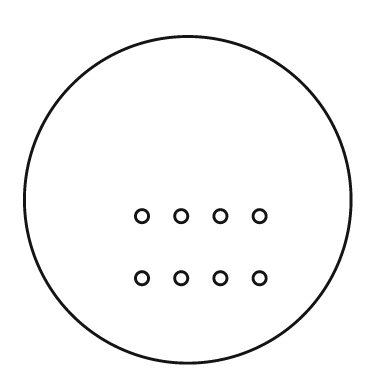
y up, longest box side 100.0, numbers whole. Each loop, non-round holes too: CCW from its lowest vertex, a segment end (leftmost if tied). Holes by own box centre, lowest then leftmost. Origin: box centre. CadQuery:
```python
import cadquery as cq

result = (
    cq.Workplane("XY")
    .moveTo(0.0, 0.0)
    .circle(50.0)
    .moveTo(-14.0, -24.0)
    .circle(2.0)
    .moveTo(-2.0, -24.0)
    .circle(2.0)
    .moveTo(10.0, -24.0)
    .circle(2.0)
    .moveTo(22.0, -24.0)
    .circle(2.0)
    .moveTo(-14.0, -5.0)
    .circle(2.0)
    .moveTo(-2.0, -5.0)
    .circle(2.0)
    .moveTo(10.0, -5.0)
    .circle(2.0)
    .moveTo(22.0, -5.0)
    .circle(2.0)
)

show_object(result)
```